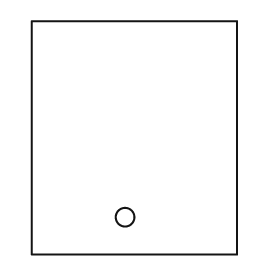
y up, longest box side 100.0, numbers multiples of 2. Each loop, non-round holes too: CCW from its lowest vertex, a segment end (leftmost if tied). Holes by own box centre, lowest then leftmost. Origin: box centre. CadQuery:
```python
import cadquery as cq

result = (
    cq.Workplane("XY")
    .moveTo(-44.0, -50.0)
    .lineTo(44.0, -50.0)
    .lineTo(44.0, 50.0)
    .lineTo(-44.0, 50.0)
    .close()
    .moveTo(-4.0, -34.0)
    .circle(4.0)
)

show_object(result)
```